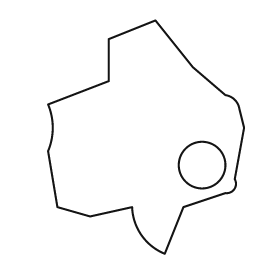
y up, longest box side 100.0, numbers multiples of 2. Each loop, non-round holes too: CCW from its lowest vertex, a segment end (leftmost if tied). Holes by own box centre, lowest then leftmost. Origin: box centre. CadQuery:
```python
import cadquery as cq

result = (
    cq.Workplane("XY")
    .moveTo(8.0, -50.0)
    .lineTo(16.0, -30.0)
    .lineTo(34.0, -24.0)
    .threePointArc((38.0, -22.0), (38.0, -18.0))
    .lineTo(42.0, 4.0)
    .lineTo(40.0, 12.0)
    .threePointArc((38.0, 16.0), (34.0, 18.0))
    .lineTo(20.0, 30.0)
    .lineTo(4.0, 50.0)
    .lineTo(-16.0, 42.0)
    .lineTo(-16.0, 24.0)
    .lineTo(-42.0, 14.0)
    .threePointArc((-40.0, 4.0), (-42.0, -6.0))
    .lineTo(-38.0, -30.0)
    .lineTo(-24.0, -34.0)
    .lineTo(-6.0, -30.0)
    .threePointArc((-2.0, -42.0), (8.0, -50.0))
    .close()
    .moveTo(24.0, -12.0)
    .circle(10.0)
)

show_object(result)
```